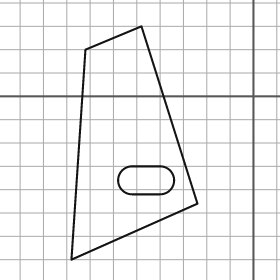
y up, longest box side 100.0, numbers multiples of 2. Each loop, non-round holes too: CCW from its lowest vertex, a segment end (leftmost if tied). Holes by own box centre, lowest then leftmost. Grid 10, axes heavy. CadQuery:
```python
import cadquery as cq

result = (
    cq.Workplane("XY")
    .moveTo(-78.0, -70.0)
    .lineTo(-24.0, -46.0)
    .lineTo(-48.0, 30.0)
    .lineTo(-72.0, 20.0)
    .close()
    .moveTo(-52.0, -42.0)
    .lineTo(-40.0, -42.0)
    .threePointArc((-34.0, -36.0), (-40.0, -30.0))
    .lineTo(-52.0, -30.0)
    .threePointArc((-58.0, -36.0), (-52.0, -42.0))
    .close()
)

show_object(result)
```